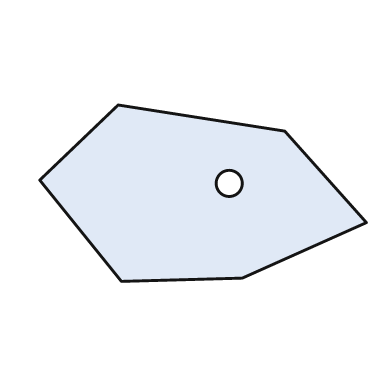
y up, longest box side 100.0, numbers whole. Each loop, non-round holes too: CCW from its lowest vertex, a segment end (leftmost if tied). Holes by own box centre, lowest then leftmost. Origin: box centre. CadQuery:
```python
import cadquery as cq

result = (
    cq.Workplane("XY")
    .moveTo(-25.0, -27.0)
    .lineTo(12.0, -26.0)
    .lineTo(50.0, -9.0)
    .lineTo(25.0, 19.0)
    .lineTo(-26.0, 27.0)
    .lineTo(-50.0, 4.0)
    .close()
    .moveTo(8.0, 3.0)
    .circle(4.0)
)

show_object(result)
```